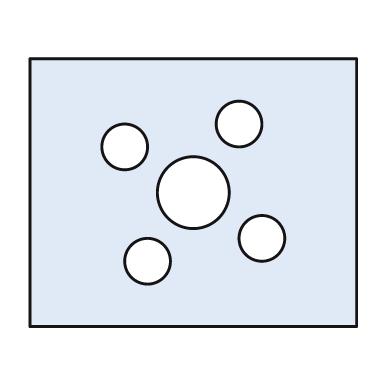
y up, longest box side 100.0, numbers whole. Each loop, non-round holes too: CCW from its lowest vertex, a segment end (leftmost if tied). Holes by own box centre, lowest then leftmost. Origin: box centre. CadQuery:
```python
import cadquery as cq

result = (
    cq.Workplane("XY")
    .moveTo(-50.0, -41.0)
    .lineTo(50.0, -41.0)
    .lineTo(50.0, 41.0)
    .lineTo(-50.0, 41.0)
    .close()
    .moveTo(-14.0, -21.0)
    .circle(7.0)
    .moveTo(21.0, -14.0)
    .circle(7.0)
    .moveTo(0.0, 0.0)
    .circle(11.0)
    .moveTo(-21.0, 14.0)
    .circle(7.0)
    .moveTo(14.0, 21.0)
    .circle(7.0)
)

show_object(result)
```